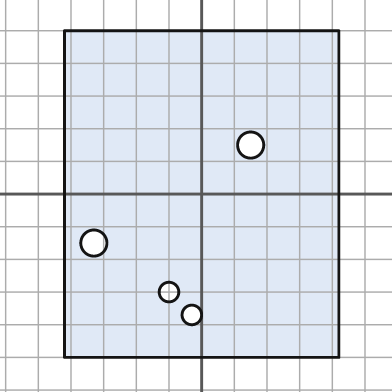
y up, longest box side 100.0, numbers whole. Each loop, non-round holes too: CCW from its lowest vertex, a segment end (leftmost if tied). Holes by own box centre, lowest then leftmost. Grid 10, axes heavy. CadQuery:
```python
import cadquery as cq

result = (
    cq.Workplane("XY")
    .moveTo(-42.0, -50.0)
    .lineTo(42.0, -50.0)
    .lineTo(42.0, 50.0)
    .lineTo(-42.0, 50.0)
    .close()
    .moveTo(-3.0, -37.0)
    .circle(3.0)
    .moveTo(-10.0, -30.0)
    .circle(3.0)
    .moveTo(-33.0, -15.0)
    .circle(4.0)
    .moveTo(15.0, 15.0)
    .circle(4.0)
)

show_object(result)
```